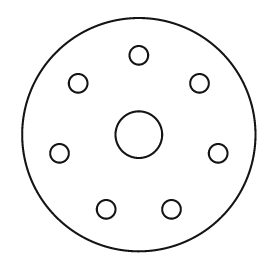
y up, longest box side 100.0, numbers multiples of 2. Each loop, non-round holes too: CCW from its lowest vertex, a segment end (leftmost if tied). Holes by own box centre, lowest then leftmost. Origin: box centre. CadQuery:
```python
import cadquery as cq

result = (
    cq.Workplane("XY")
    .moveTo(0.0, 0.0)
    .circle(50.0)
    .moveTo(-14.0, -32.0)
    .circle(4.0)
    .moveTo(14.0, -32.0)
    .circle(4.0)
    .moveTo(-34.0, -8.0)
    .circle(4.0)
    .moveTo(34.0, -8.0)
    .circle(4.0)
    .moveTo(0.0, 0.0)
    .circle(10.0)
    .moveTo(-26.0, 22.0)
    .circle(4.0)
    .moveTo(26.0, 22.0)
    .circle(4.0)
    .moveTo(0.0, 34.0)
    .circle(4.0)
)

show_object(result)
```